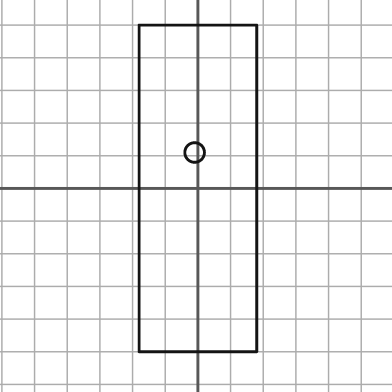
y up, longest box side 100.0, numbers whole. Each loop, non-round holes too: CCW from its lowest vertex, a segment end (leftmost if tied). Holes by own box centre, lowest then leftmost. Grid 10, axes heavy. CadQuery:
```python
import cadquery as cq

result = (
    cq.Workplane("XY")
    .moveTo(-18.0, -50.0)
    .lineTo(18.0, -50.0)
    .lineTo(18.0, 50.0)
    .lineTo(-18.0, 50.0)
    .close()
    .moveTo(-1.0, 11.0)
    .circle(3.0)
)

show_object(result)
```